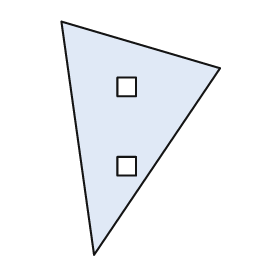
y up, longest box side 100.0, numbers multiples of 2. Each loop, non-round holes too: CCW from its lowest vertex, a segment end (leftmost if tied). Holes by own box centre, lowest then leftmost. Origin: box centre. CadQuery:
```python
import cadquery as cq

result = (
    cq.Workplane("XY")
    .moveTo(-20.0, -50.0)
    .lineTo(34.0, 30.0)
    .lineTo(-34.0, 50.0)
    .close()
    .moveTo(-10.0, -16.0)
    .lineTo(-2.0, -16.0)
    .lineTo(-2.0, -8.0)
    .lineTo(-10.0, -8.0)
    .close()
    .moveTo(-10.0, 18.0)
    .lineTo(-2.0, 18.0)
    .lineTo(-2.0, 26.0)
    .lineTo(-10.0, 26.0)
    .close()
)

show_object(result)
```